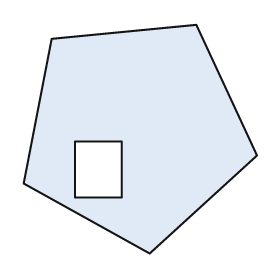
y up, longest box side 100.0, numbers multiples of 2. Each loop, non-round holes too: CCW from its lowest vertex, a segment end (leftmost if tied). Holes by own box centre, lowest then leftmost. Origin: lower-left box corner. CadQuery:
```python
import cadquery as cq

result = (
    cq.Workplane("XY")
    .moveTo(54.0, 0.0)
    .lineTo(100.0, 42.0)
    .lineTo(74.0, 98.0)
    .lineTo(12.0, 92.0)
    .lineTo(0.0, 30.0)
    .close()
    .moveTo(22.0, 24.0)
    .lineTo(42.0, 24.0)
    .lineTo(42.0, 48.0)
    .lineTo(22.0, 48.0)
    .close()
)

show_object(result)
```